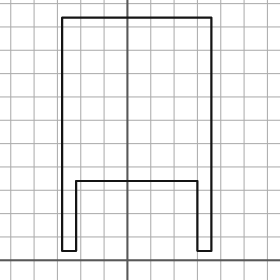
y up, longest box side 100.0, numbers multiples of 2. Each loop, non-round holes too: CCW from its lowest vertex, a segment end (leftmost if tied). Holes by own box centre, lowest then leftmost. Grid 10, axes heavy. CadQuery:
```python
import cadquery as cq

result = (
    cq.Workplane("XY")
    .moveTo(-28.0, 4.0)
    .lineTo(-22.0, 4.0)
    .lineTo(-22.0, 34.0)
    .lineTo(30.0, 34.0)
    .lineTo(30.0, 4.0)
    .lineTo(36.0, 4.0)
    .lineTo(36.0, 104.0)
    .lineTo(-28.0, 104.0)
    .close()
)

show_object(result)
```